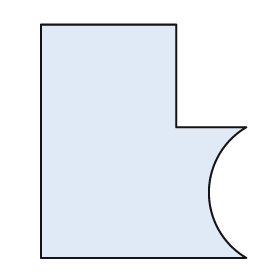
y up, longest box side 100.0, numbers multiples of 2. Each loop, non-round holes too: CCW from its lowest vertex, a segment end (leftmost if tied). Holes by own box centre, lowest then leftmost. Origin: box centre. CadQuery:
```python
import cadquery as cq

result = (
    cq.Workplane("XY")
    .moveTo(-44.0, -50.0)
    .lineTo(44.0, -50.0)
    .threePointArc((28.0, -22.0), (44.0, 6.0))
    .lineTo(14.0, 6.0)
    .lineTo(14.0, 50.0)
    .lineTo(-44.0, 50.0)
    .close()
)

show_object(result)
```